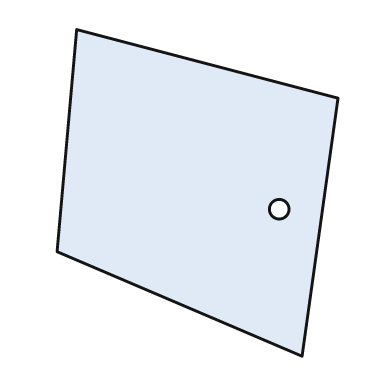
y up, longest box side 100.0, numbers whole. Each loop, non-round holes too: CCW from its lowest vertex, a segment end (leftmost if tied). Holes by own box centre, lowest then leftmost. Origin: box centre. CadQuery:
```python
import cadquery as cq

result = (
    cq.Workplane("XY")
    .moveTo(32.0, -50.0)
    .lineTo(43.0, 29.0)
    .lineTo(-37.0, 50.0)
    .lineTo(-43.0, -18.0)
    .close()
    .moveTo(25.0, -5.0)
    .circle(3.0)
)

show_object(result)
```